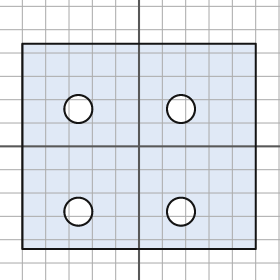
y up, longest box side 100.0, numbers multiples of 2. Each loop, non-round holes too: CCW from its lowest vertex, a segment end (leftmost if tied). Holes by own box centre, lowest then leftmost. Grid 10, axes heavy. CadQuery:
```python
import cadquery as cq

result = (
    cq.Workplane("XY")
    .moveTo(-50.0, -44.0)
    .lineTo(50.0, -44.0)
    .lineTo(50.0, 44.0)
    .lineTo(-50.0, 44.0)
    .close()
    .moveTo(-26.0, -28.0)
    .circle(6.0)
    .moveTo(18.0, -28.0)
    .circle(6.0)
    .moveTo(-26.0, 16.0)
    .circle(6.0)
    .moveTo(18.0, 16.0)
    .circle(6.0)
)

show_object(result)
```